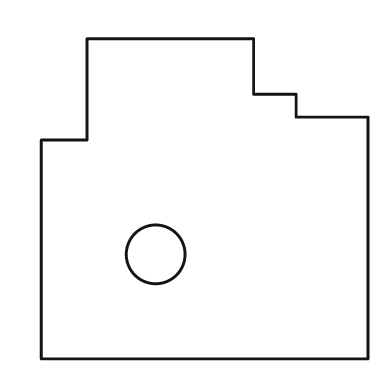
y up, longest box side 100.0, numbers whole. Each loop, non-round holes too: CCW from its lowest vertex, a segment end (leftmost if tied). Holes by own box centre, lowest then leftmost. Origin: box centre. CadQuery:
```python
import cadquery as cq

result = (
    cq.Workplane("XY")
    .moveTo(-50.0, -49.0)
    .lineTo(50.0, -49.0)
    .lineTo(50.0, 25.0)
    .lineTo(28.0, 25.0)
    .lineTo(28.0, 32.0)
    .lineTo(15.0, 32.0)
    .lineTo(15.0, 49.0)
    .lineTo(-36.0, 49.0)
    .lineTo(-36.0, 18.0)
    .lineTo(-50.0, 18.0)
    .close()
    .moveTo(-15.0, -17.0)
    .circle(9.0)
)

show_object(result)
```